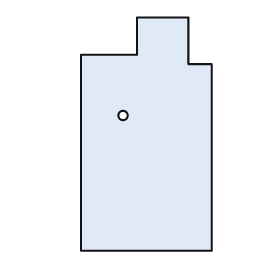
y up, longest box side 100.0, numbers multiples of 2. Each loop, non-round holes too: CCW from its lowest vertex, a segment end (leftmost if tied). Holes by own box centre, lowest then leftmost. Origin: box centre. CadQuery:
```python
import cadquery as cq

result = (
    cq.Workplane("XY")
    .moveTo(-28.0, -50.0)
    .lineTo(28.0, -50.0)
    .lineTo(28.0, 30.0)
    .lineTo(18.0, 30.0)
    .lineTo(18.0, 50.0)
    .lineTo(-4.0, 50.0)
    .lineTo(-4.0, 34.0)
    .lineTo(-28.0, 34.0)
    .close()
    .moveTo(-10.0, 8.0)
    .circle(2.0)
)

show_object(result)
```